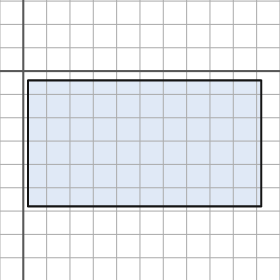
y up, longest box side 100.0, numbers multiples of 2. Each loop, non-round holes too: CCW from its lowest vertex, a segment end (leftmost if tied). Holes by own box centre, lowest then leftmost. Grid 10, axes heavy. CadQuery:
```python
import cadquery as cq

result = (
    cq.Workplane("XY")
    .moveTo(2.0, -58.0)
    .lineTo(102.0, -58.0)
    .lineTo(102.0, -4.0)
    .lineTo(2.0, -4.0)
    .close()
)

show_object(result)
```